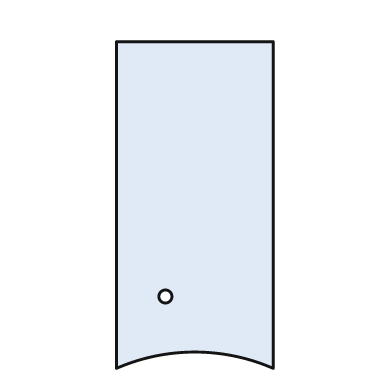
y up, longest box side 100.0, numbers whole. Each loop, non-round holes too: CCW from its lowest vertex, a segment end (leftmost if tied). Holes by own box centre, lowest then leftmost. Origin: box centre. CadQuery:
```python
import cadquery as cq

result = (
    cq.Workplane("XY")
    .moveTo(-24.0, -50.0)
    .threePointArc((0.0, -45.0), (24.0, -50.0))
    .lineTo(24.0, 50.0)
    .lineTo(-24.0, 50.0)
    .close()
    .moveTo(-9.0, -28.0)
    .circle(2.0)
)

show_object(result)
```